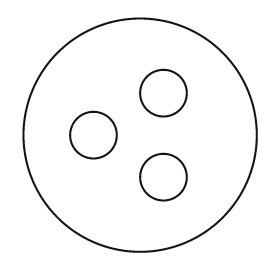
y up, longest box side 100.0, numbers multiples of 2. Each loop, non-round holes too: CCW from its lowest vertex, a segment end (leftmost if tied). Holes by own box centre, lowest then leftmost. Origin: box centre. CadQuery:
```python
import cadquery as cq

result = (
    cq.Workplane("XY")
    .moveTo(0.0, 0.0)
    .circle(50.0)
    .moveTo(10.0, -18.0)
    .circle(10.0)
    .moveTo(-20.0, 0.0)
    .circle(10.0)
    .moveTo(10.0, 18.0)
    .circle(10.0)
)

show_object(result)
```